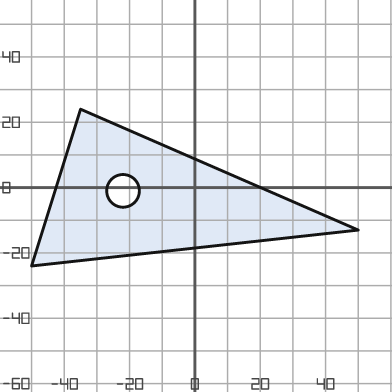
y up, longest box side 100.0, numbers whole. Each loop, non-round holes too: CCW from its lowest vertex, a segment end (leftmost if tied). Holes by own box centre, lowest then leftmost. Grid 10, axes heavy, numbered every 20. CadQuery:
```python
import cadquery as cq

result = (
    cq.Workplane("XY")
    .moveTo(-50.0, -24.0)
    .lineTo(50.0, -13.0)
    .lineTo(-35.0, 24.0)
    .close()
    .moveTo(-22.0, -1.0)
    .circle(5.0)
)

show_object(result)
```